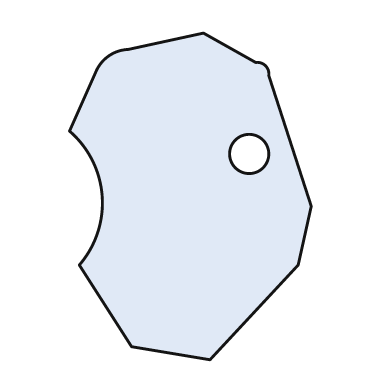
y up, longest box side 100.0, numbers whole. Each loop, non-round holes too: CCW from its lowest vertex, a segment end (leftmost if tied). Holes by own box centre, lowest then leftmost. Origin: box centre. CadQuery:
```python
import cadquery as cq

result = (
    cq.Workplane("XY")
    .moveTo(6.0, -50.0)
    .lineTo(33.0, -21.0)
    .lineTo(37.0, -3.0)
    .lineTo(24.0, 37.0)
    .threePointArc((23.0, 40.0), (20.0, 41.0))
    .lineTo(4.0, 50.0)
    .lineTo(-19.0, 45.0)
    .threePointArc((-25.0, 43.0), (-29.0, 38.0))
    .lineTo(-37.0, 20.0)
    .threePointArc((-27.0, 0.0), (-34.0, -21.0))
    .lineTo(-18.0, -46.0)
    .close()
    .moveTo(18.0, 13.0)
    .circle(6.0)
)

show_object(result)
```